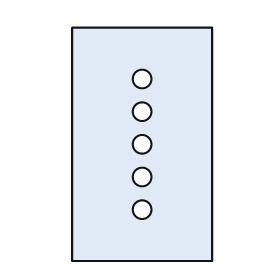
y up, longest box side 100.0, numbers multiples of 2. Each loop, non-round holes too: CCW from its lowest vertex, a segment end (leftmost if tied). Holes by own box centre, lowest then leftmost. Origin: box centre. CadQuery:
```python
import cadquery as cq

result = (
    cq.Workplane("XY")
    .moveTo(-30.0, -50.0)
    .lineTo(30.0, -50.0)
    .lineTo(30.0, 50.0)
    .lineTo(-30.0, 50.0)
    .close()
    .moveTo(0.0, -28.0)
    .circle(4.0)
    .moveTo(0.0, -14.0)
    .circle(4.0)
    .moveTo(0.0, 0.0)
    .circle(4.0)
    .moveTo(0.0, 14.0)
    .circle(4.0)
    .moveTo(0.0, 28.0)
    .circle(4.0)
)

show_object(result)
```